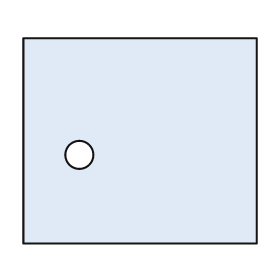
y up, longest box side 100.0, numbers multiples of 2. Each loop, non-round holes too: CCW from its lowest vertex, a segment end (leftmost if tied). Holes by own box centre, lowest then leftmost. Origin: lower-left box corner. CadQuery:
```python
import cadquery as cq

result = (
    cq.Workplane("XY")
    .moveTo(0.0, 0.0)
    .lineTo(100.0, 0.0)
    .lineTo(100.0, 88.0)
    .lineTo(0.0, 88.0)
    .close()
    .moveTo(24.0, 38.0)
    .circle(6.0)
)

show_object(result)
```